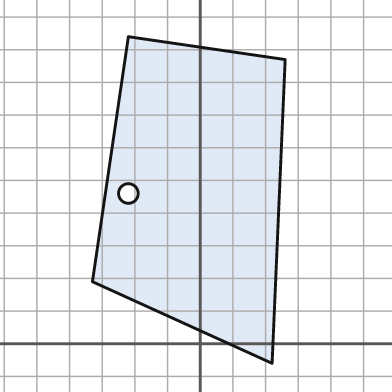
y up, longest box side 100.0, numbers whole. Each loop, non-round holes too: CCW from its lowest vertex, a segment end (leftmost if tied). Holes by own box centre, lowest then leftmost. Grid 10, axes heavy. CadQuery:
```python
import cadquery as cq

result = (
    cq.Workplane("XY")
    .moveTo(22.0, -6.0)
    .lineTo(26.0, 87.0)
    .lineTo(-22.0, 94.0)
    .lineTo(-33.0, 19.0)
    .close()
    .moveTo(-22.0, 46.0)
    .circle(3.0)
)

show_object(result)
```